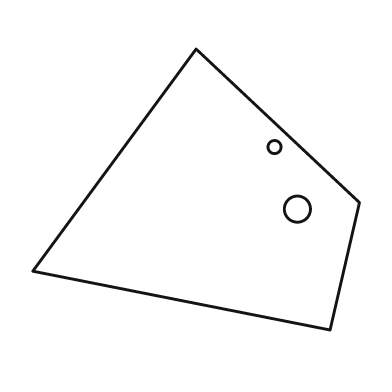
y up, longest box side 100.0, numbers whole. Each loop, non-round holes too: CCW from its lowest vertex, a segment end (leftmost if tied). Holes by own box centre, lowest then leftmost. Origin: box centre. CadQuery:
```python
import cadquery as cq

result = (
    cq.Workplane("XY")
    .moveTo(41.0, -43.0)
    .lineTo(50.0, -4.0)
    .lineTo(0.0, 43.0)
    .lineTo(-50.0, -25.0)
    .close()
    .moveTo(31.0, -6.0)
    .circle(4.0)
    .moveTo(24.0, 13.0)
    .circle(2.0)
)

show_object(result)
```